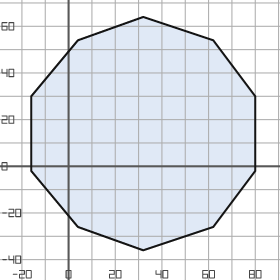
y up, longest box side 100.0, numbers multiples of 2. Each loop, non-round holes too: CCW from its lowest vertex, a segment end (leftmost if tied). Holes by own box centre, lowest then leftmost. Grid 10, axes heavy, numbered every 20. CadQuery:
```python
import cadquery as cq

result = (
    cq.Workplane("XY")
    .moveTo(32.0, -36.0)
    .lineTo(62.0, -26.0)
    .lineTo(80.0, -2.0)
    .lineTo(80.0, 30.0)
    .lineTo(62.0, 54.0)
    .lineTo(32.0, 64.0)
    .lineTo(4.0, 54.0)
    .lineTo(-16.0, 30.0)
    .lineTo(-16.0, -2.0)
    .lineTo(4.0, -26.0)
    .close()
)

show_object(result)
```